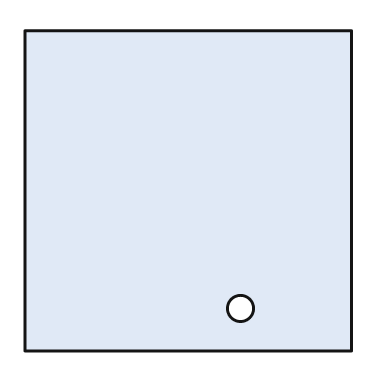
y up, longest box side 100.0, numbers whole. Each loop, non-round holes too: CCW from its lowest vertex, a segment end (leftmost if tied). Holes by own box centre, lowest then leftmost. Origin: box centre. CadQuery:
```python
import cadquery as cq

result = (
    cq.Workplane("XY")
    .moveTo(-50.0, -49.0)
    .lineTo(50.0, -49.0)
    .lineTo(50.0, 49.0)
    .lineTo(-50.0, 49.0)
    .close()
    .moveTo(16.0, -36.0)
    .circle(4.0)
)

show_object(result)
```